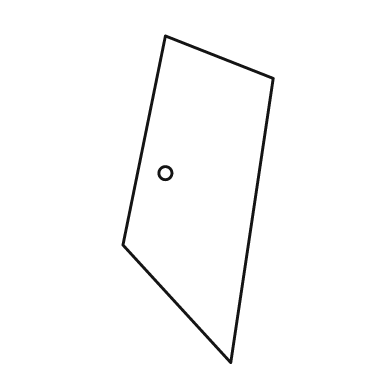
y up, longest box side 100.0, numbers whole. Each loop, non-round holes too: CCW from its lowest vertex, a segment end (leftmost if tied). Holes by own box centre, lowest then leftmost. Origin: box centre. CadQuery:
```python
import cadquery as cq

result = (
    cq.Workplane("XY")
    .moveTo(10.0, -50.0)
    .lineTo(23.0, 37.0)
    .lineTo(-10.0, 50.0)
    .lineTo(-23.0, -14.0)
    .close()
    .moveTo(-10.0, 8.0)
    .circle(2.0)
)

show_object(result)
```